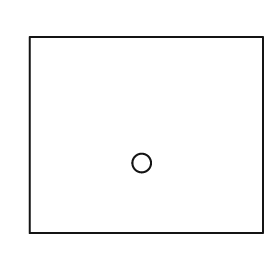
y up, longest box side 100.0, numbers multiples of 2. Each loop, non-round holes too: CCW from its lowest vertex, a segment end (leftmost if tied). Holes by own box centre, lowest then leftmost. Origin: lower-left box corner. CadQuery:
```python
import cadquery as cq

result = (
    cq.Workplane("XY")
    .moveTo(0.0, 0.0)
    .lineTo(100.0, 0.0)
    .lineTo(100.0, 84.0)
    .lineTo(0.0, 84.0)
    .close()
    .moveTo(48.0, 30.0)
    .circle(4.0)
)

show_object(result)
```